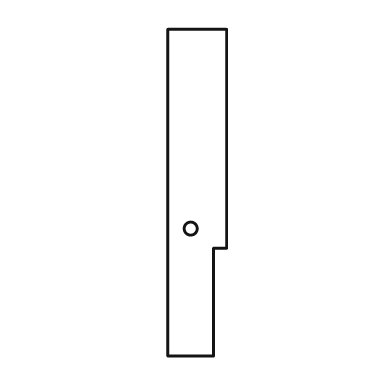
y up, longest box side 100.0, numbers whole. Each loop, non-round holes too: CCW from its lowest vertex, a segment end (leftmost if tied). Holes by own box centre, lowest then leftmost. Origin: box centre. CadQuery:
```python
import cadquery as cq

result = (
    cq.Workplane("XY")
    .moveTo(-9.0, -50.0)
    .lineTo(5.0, -50.0)
    .lineTo(5.0, -17.0)
    .lineTo(9.0, -17.0)
    .lineTo(9.0, 50.0)
    .lineTo(-9.0, 50.0)
    .close()
    .moveTo(-2.0, -11.0)
    .circle(2.0)
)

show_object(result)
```